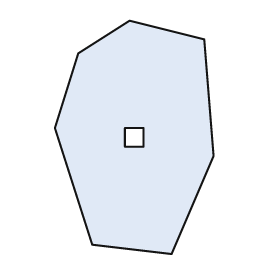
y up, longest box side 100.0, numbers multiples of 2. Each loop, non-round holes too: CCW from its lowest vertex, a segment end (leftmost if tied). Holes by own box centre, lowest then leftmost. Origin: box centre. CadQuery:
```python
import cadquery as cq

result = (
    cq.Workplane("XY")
    .moveTo(16.0, -50.0)
    .lineTo(34.0, -8.0)
    .lineTo(30.0, 42.0)
    .lineTo(-2.0, 50.0)
    .lineTo(-24.0, 36.0)
    .lineTo(-34.0, 4.0)
    .lineTo(-18.0, -46.0)
    .close()
    .moveTo(-4.0, -4.0)
    .lineTo(4.0, -4.0)
    .lineTo(4.0, 4.0)
    .lineTo(-4.0, 4.0)
    .close()
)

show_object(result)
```